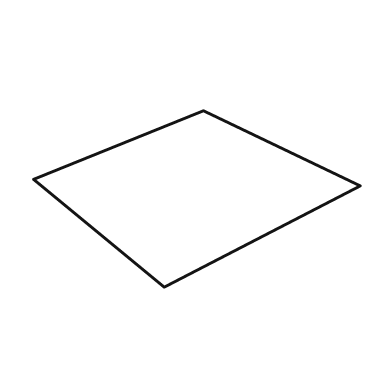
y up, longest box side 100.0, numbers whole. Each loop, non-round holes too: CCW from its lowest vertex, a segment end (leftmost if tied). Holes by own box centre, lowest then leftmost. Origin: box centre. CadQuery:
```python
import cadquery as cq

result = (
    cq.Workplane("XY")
    .moveTo(-10.0, -27.0)
    .lineTo(50.0, 4.0)
    .lineTo(2.0, 27.0)
    .lineTo(-50.0, 6.0)
    .close()
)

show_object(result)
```